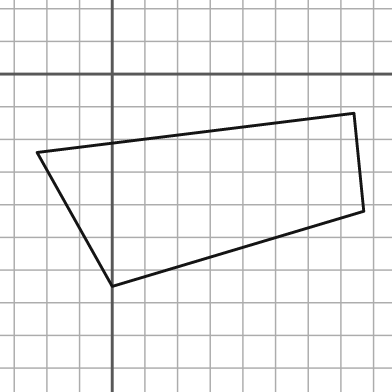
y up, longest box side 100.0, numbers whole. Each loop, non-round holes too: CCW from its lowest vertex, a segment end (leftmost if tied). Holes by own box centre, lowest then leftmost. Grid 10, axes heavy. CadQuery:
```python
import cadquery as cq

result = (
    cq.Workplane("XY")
    .moveTo(0.0, -65.0)
    .lineTo(77.0, -42.0)
    .lineTo(74.0, -12.0)
    .lineTo(-23.0, -24.0)
    .close()
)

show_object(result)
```